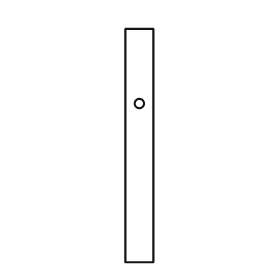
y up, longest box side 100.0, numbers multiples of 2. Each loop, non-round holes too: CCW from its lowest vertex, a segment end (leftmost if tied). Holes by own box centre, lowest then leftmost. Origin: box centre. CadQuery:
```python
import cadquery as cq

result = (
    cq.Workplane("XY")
    .moveTo(-6.0, -50.0)
    .lineTo(6.0, -50.0)
    .lineTo(6.0, 50.0)
    .lineTo(-6.0, 50.0)
    .close()
    .moveTo(0.0, 18.0)
    .circle(2.0)
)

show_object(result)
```